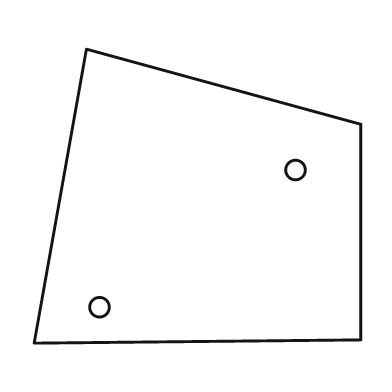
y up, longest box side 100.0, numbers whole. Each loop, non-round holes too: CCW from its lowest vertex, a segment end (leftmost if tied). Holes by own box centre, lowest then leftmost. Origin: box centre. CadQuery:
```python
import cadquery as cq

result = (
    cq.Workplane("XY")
    .moveTo(-50.0, -45.0)
    .lineTo(50.0, -44.0)
    .lineTo(50.0, 22.0)
    .lineTo(-34.0, 45.0)
    .close()
    .moveTo(-30.0, -34.0)
    .circle(3.0)
    .moveTo(30.0, 8.0)
    .circle(3.0)
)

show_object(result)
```